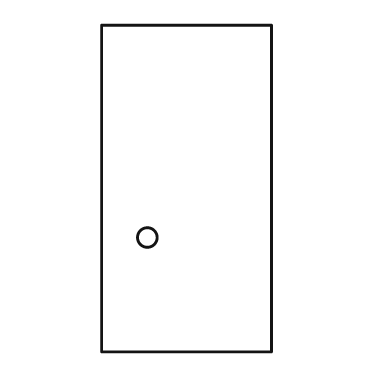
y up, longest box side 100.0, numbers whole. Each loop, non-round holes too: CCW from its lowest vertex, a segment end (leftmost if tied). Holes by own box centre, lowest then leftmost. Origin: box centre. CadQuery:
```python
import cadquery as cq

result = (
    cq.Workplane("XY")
    .moveTo(-26.0, -50.0)
    .lineTo(26.0, -50.0)
    .lineTo(26.0, 50.0)
    .lineTo(-26.0, 50.0)
    .close()
    .moveTo(-12.0, -15.0)
    .circle(3.0)
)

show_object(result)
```